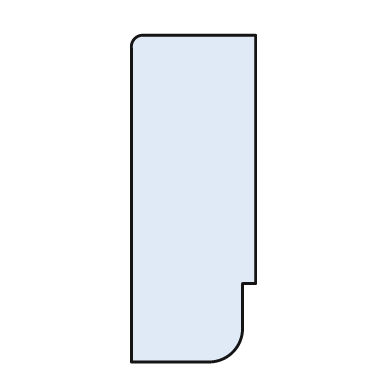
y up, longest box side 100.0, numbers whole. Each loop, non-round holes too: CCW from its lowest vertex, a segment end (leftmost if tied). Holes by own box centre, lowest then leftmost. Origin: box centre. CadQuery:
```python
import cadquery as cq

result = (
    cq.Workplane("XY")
    .moveTo(-19.0, -50.0)
    .lineTo(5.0, -50.0)
    .threePointArc((12.0, -47.0), (15.0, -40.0))
    .lineTo(15.0, -26.0)
    .lineTo(19.0, -26.0)
    .lineTo(19.0, 50.0)
    .lineTo(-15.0, 50.0)
    .threePointArc((-18.0, 49.0), (-19.0, 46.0))
    .close()
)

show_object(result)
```